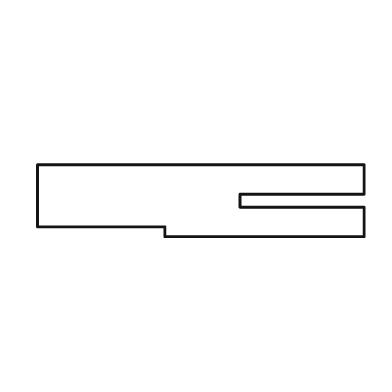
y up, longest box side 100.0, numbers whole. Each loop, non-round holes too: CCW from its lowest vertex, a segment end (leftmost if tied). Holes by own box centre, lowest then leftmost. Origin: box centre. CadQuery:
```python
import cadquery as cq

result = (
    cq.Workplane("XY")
    .moveTo(-11.0, -11.0)
    .lineTo(50.0, -11.0)
    .lineTo(50.0, -2.0)
    .lineTo(12.0, -2.0)
    .lineTo(12.0, 2.0)
    .lineTo(50.0, 2.0)
    .lineTo(50.0, 11.0)
    .lineTo(-50.0, 11.0)
    .lineTo(-50.0, -8.0)
    .lineTo(-11.0, -8.0)
    .close()
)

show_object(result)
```